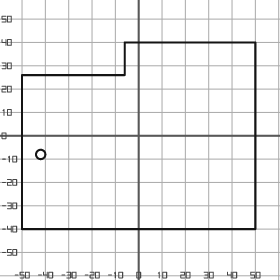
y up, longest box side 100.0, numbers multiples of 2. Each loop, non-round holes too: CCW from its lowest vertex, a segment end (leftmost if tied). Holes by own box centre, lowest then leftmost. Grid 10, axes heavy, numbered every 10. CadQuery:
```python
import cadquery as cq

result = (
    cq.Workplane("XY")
    .moveTo(-50.0, -40.0)
    .lineTo(50.0, -40.0)
    .lineTo(50.0, 40.0)
    .lineTo(-6.0, 40.0)
    .lineTo(-6.0, 26.0)
    .lineTo(-50.0, 26.0)
    .close()
    .moveTo(-42.0, -8.0)
    .circle(2.0)
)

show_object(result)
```